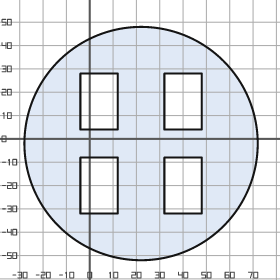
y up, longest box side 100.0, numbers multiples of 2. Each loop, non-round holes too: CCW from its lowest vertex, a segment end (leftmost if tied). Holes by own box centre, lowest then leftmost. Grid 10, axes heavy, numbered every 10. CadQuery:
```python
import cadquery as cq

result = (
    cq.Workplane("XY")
    .moveTo(22.0, -2.0)
    .circle(50.0)
    .moveTo(-4.0, -32.0)
    .lineTo(12.0, -32.0)
    .lineTo(12.0, -8.0)
    .lineTo(-4.0, -8.0)
    .close()
    .moveTo(32.0, -32.0)
    .lineTo(48.0, -32.0)
    .lineTo(48.0, -8.0)
    .lineTo(32.0, -8.0)
    .close()
    .moveTo(-4.0, 4.0)
    .lineTo(12.0, 4.0)
    .lineTo(12.0, 28.0)
    .lineTo(-4.0, 28.0)
    .close()
    .moveTo(32.0, 4.0)
    .lineTo(48.0, 4.0)
    .lineTo(48.0, 28.0)
    .lineTo(32.0, 28.0)
    .close()
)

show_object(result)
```